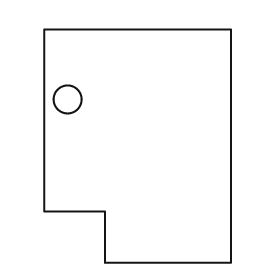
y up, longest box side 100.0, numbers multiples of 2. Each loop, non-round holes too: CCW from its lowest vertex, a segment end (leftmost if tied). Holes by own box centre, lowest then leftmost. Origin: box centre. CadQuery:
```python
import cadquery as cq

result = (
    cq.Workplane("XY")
    .moveTo(-14.0, -50.0)
    .lineTo(40.0, -50.0)
    .lineTo(40.0, 50.0)
    .lineTo(-40.0, 50.0)
    .lineTo(-40.0, -28.0)
    .lineTo(-14.0, -28.0)
    .close()
    .moveTo(-30.0, 20.0)
    .circle(6.0)
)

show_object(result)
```